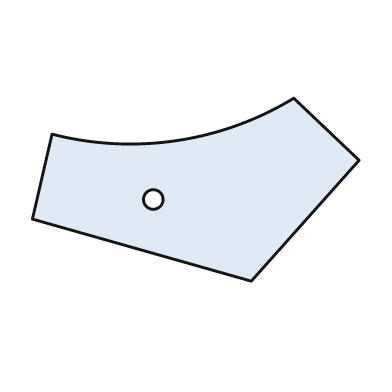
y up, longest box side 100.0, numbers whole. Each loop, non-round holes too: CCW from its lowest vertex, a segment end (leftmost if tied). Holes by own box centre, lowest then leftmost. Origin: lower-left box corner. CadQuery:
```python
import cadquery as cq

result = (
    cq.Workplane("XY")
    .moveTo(67.0, 0.0)
    .lineTo(100.0, 37.0)
    .lineTo(80.0, 56.0)
    .threePointArc((44.0, 43.0), (6.0, 45.0))
    .lineTo(0.0, 19.0)
    .close()
    .moveTo(37.0, 25.0)
    .circle(3.0)
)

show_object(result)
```